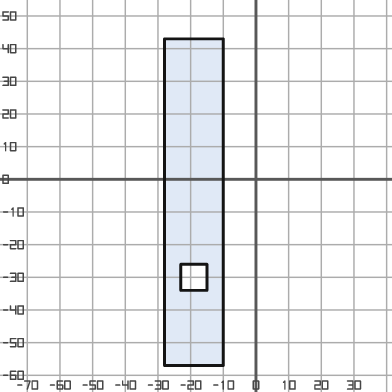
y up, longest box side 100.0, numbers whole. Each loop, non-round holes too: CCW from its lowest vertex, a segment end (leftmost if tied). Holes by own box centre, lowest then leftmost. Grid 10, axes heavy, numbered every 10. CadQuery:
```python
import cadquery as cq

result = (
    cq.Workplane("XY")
    .moveTo(-28.0, -57.0)
    .lineTo(-10.0, -57.0)
    .lineTo(-10.0, 43.0)
    .lineTo(-28.0, 43.0)
    .close()
    .moveTo(-23.0, -34.0)
    .lineTo(-15.0, -34.0)
    .lineTo(-15.0, -26.0)
    .lineTo(-23.0, -26.0)
    .close()
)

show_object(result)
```